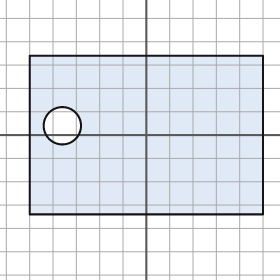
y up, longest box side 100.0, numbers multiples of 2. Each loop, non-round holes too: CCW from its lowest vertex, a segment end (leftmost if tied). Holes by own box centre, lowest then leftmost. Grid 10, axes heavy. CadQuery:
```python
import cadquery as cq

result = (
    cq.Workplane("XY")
    .moveTo(-50.0, -34.0)
    .lineTo(50.0, -34.0)
    .lineTo(50.0, 34.0)
    .lineTo(-50.0, 34.0)
    .close()
    .moveTo(-36.0, 4.0)
    .circle(8.0)
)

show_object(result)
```